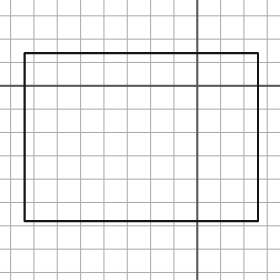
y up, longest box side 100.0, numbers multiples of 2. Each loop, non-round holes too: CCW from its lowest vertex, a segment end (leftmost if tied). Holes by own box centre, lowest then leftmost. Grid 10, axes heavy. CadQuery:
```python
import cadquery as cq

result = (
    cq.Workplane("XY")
    .moveTo(-74.0, -58.0)
    .lineTo(26.0, -58.0)
    .lineTo(26.0, 14.0)
    .lineTo(-74.0, 14.0)
    .close()
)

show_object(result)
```